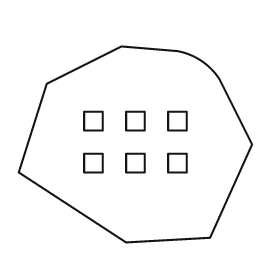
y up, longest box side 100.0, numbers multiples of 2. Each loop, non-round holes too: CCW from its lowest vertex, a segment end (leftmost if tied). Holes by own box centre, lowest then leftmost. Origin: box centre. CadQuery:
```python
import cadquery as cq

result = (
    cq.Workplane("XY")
    .moveTo(-4.0, -42.0)
    .lineTo(32.0, -40.0)
    .lineTo(50.0, 0.0)
    .lineTo(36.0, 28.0)
    .threePointArc((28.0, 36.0), (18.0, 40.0))
    .lineTo(-6.0, 42.0)
    .lineTo(-38.0, 26.0)
    .lineTo(-50.0, -12.0)
    .close()
    .moveTo(-22.0, -12.0)
    .lineTo(-14.0, -12.0)
    .lineTo(-14.0, -4.0)
    .lineTo(-22.0, -4.0)
    .close()
    .moveTo(-4.0, -12.0)
    .lineTo(4.0, -12.0)
    .lineTo(4.0, -4.0)
    .lineTo(-4.0, -4.0)
    .close()
    .moveTo(14.0, -12.0)
    .lineTo(22.0, -12.0)
    .lineTo(22.0, -4.0)
    .lineTo(14.0, -4.0)
    .close()
    .moveTo(-22.0, 6.0)
    .lineTo(-14.0, 6.0)
    .lineTo(-14.0, 14.0)
    .lineTo(-22.0, 14.0)
    .close()
    .moveTo(-4.0, 6.0)
    .lineTo(4.0, 6.0)
    .lineTo(4.0, 14.0)
    .lineTo(-4.0, 14.0)
    .close()
    .moveTo(14.0, 6.0)
    .lineTo(22.0, 6.0)
    .lineTo(22.0, 14.0)
    .lineTo(14.0, 14.0)
    .close()
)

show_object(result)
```